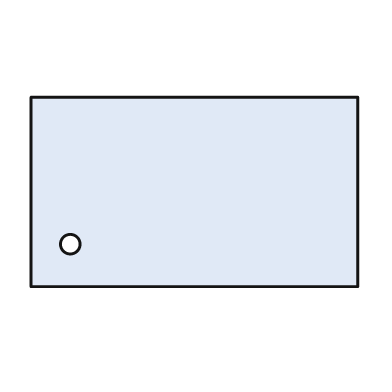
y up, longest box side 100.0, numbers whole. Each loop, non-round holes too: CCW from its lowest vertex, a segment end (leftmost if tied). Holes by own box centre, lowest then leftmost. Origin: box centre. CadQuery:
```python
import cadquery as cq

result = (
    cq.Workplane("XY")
    .moveTo(-50.0, -29.0)
    .lineTo(50.0, -29.0)
    .lineTo(50.0, 29.0)
    .lineTo(-50.0, 29.0)
    .close()
    .moveTo(-38.0, -16.0)
    .circle(3.0)
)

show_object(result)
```